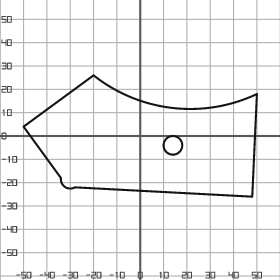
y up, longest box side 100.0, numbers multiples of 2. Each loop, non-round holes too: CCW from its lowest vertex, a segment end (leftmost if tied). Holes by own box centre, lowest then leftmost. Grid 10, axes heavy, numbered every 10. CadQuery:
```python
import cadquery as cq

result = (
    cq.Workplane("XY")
    .moveTo(48.0, -26.0)
    .lineTo(50.0, 18.0)
    .threePointArc((14.0, 12.0), (-20.0, 26.0))
    .lineTo(-50.0, 4.0)
    .lineTo(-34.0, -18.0)
    .threePointArc((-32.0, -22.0), (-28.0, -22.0))
    .close()
    .moveTo(14.0, -4.0)
    .circle(4.0)
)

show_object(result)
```